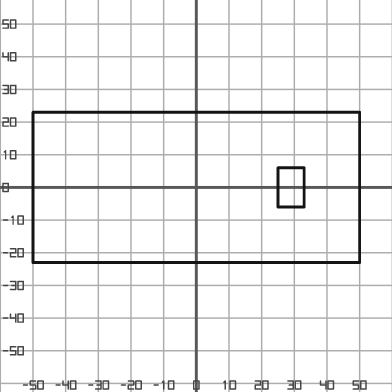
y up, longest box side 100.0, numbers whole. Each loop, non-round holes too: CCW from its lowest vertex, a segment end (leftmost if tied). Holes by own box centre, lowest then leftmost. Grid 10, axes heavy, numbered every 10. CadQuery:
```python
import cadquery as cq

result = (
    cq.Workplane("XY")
    .moveTo(-50.0, -23.0)
    .lineTo(50.0, -23.0)
    .lineTo(50.0, 23.0)
    .lineTo(-50.0, 23.0)
    .close()
    .moveTo(25.0, -6.0)
    .lineTo(33.0, -6.0)
    .lineTo(33.0, 6.0)
    .lineTo(25.0, 6.0)
    .close()
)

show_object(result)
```